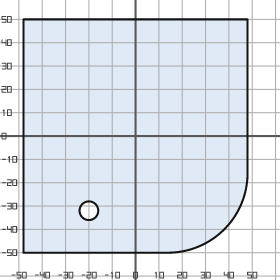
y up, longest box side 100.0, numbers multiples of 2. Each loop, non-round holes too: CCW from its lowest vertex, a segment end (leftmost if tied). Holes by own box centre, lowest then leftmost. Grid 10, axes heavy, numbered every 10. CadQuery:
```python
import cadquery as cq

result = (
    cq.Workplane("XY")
    .moveTo(-48.0, -50.0)
    .lineTo(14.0, -50.0)
    .threePointArc((38.0, -40.0), (48.0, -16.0))
    .lineTo(48.0, 50.0)
    .lineTo(-48.0, 50.0)
    .close()
    .moveTo(-20.0, -32.0)
    .circle(4.0)
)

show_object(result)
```